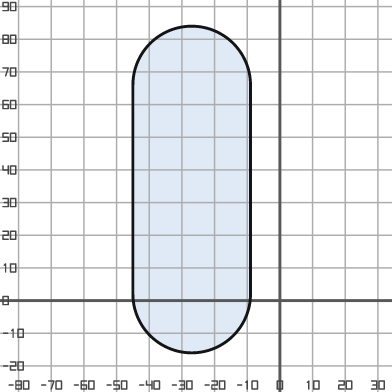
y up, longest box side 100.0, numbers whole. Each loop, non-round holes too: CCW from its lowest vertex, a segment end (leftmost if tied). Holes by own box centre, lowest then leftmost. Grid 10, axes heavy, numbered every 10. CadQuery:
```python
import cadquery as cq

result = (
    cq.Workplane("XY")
    .moveTo(-45.0, 2.0)
    .threePointArc((-27.0, -16.0), (-9.0, 2.0))
    .lineTo(-9.0, 66.0)
    .threePointArc((-27.0, 84.0), (-45.0, 66.0))
    .close()
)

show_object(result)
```